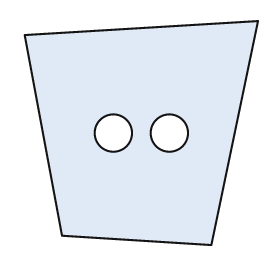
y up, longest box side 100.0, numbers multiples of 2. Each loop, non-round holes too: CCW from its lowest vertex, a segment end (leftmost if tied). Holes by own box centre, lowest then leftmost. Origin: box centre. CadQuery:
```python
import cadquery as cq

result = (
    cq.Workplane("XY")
    .moveTo(30.0, -48.0)
    .lineTo(50.0, 48.0)
    .lineTo(-50.0, 42.0)
    .lineTo(-34.0, -44.0)
    .close()
    .moveTo(-12.0, 0.0)
    .circle(8.0)
    .moveTo(12.0, 0.0)
    .circle(8.0)
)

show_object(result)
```